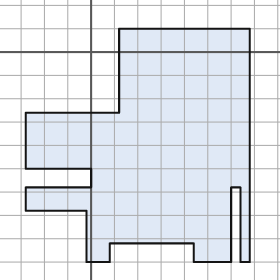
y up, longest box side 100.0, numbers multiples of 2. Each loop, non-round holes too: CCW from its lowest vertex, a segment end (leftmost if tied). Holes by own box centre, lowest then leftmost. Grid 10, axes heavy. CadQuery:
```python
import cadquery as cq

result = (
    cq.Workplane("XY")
    .moveTo(-2.0, -90.0)
    .lineTo(8.0, -90.0)
    .lineTo(8.0, -82.0)
    .lineTo(44.0, -82.0)
    .lineTo(44.0, -90.0)
    .lineTo(60.0, -90.0)
    .lineTo(60.0, -58.0)
    .lineTo(64.0, -58.0)
    .lineTo(64.0, -90.0)
    .lineTo(68.0, -90.0)
    .lineTo(68.0, 10.0)
    .lineTo(12.0, 10.0)
    .lineTo(12.0, -26.0)
    .lineTo(-28.0, -26.0)
    .lineTo(-28.0, -50.0)
    .lineTo(0.0, -50.0)
    .lineTo(0.0, -58.0)
    .lineTo(-28.0, -58.0)
    .lineTo(-28.0, -68.0)
    .lineTo(-2.0, -68.0)
    .close()
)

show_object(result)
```